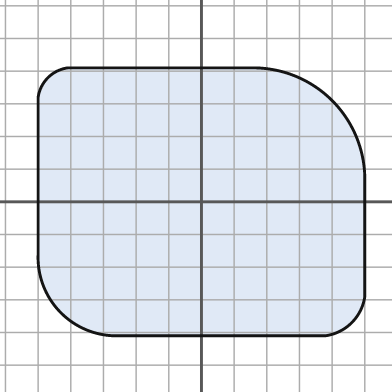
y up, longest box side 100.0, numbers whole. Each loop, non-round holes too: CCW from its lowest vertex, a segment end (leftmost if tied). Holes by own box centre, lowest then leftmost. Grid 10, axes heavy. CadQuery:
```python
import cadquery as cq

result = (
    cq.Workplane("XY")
    .moveTo(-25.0, -41.0)
    .lineTo(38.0, -41.0)
    .threePointArc((46.0, -37.0), (50.0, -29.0))
    .lineTo(50.0, 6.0)
    .threePointArc((40.0, 31.0), (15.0, 41.0))
    .lineTo(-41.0, 41.0)
    .threePointArc((-47.0, 38.0), (-50.0, 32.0))
    .lineTo(-50.0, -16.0)
    .threePointArc((-43.0, -34.0), (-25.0, -41.0))
    .close()
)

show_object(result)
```